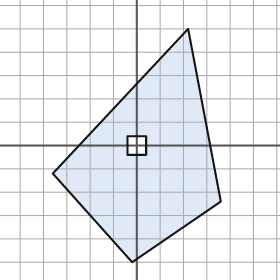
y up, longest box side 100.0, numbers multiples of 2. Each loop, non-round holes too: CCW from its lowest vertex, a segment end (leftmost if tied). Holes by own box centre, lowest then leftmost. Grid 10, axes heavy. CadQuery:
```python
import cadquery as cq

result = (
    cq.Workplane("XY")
    .moveTo(-2.0, -50.0)
    .lineTo(36.0, -24.0)
    .lineTo(22.0, 50.0)
    .lineTo(-36.0, -12.0)
    .close()
    .moveTo(-4.0, -4.0)
    .lineTo(4.0, -4.0)
    .lineTo(4.0, 4.0)
    .lineTo(-4.0, 4.0)
    .close()
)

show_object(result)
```